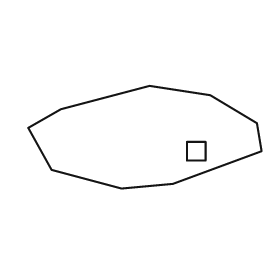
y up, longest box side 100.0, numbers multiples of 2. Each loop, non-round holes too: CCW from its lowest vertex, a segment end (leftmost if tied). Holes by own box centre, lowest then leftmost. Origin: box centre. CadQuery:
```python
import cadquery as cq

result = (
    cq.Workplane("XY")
    .moveTo(-10.0, -22.0)
    .lineTo(12.0, -20.0)
    .lineTo(50.0, -6.0)
    .lineTo(48.0, 6.0)
    .lineTo(28.0, 18.0)
    .lineTo(2.0, 22.0)
    .lineTo(-36.0, 12.0)
    .lineTo(-50.0, 4.0)
    .lineTo(-40.0, -14.0)
    .close()
    .moveTo(18.0, -10.0)
    .lineTo(26.0, -10.0)
    .lineTo(26.0, -2.0)
    .lineTo(18.0, -2.0)
    .close()
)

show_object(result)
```